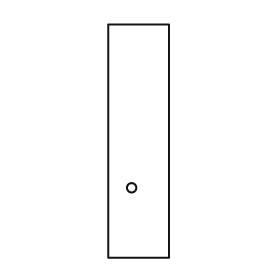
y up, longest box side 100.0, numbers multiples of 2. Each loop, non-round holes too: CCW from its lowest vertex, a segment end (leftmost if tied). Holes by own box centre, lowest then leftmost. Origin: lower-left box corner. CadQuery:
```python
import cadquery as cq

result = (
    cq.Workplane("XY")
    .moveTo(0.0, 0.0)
    .lineTo(26.0, 0.0)
    .lineTo(26.0, 100.0)
    .lineTo(0.0, 100.0)
    .close()
    .moveTo(10.0, 30.0)
    .circle(2.0)
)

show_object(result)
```